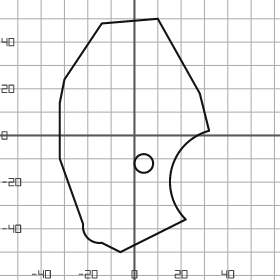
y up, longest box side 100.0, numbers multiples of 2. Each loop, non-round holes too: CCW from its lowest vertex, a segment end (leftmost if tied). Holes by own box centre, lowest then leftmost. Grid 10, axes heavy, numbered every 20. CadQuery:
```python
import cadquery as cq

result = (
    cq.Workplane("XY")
    .moveTo(-6.0, -50.0)
    .lineTo(22.0, -36.0)
    .threePointArc((16.0, -14.0), (32.0, 2.0))
    .lineTo(28.0, 18.0)
    .lineTo(10.0, 50.0)
    .lineTo(-14.0, 48.0)
    .lineTo(-30.0, 24.0)
    .lineTo(-32.0, 14.0)
    .lineTo(-32.0, -10.0)
    .lineTo(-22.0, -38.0)
    .threePointArc((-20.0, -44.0), (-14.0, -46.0))
    .close()
    .moveTo(4.0, -12.0)
    .circle(4.0)
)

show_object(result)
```